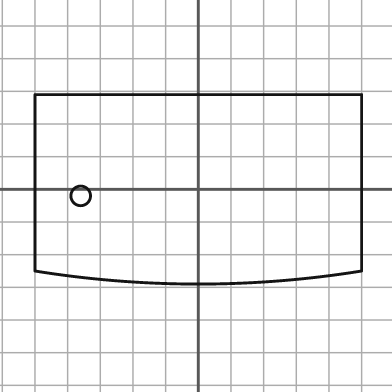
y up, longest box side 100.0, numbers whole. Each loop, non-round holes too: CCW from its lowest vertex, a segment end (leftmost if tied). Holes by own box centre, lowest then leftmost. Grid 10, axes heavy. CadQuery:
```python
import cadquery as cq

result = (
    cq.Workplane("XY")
    .moveTo(-50.0, -25.0)
    .threePointArc((0.0, -29.0), (50.0, -25.0))
    .lineTo(50.0, 29.0)
    .lineTo(-50.0, 29.0)
    .close()
    .moveTo(-36.0, -2.0)
    .circle(3.0)
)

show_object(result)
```